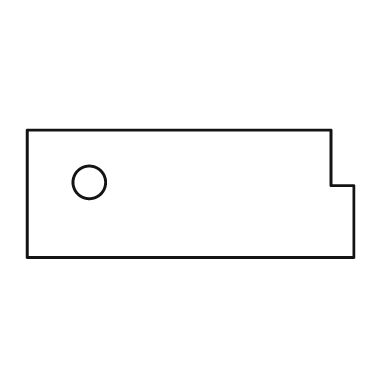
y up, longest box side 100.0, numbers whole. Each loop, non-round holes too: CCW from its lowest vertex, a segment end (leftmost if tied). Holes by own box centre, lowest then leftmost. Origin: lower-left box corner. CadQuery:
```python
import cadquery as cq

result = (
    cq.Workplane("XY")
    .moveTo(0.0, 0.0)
    .lineTo(100.0, 0.0)
    .lineTo(100.0, 22.0)
    .lineTo(93.0, 22.0)
    .lineTo(93.0, 39.0)
    .lineTo(0.0, 39.0)
    .close()
    .moveTo(19.0, 23.0)
    .circle(5.0)
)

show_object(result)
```